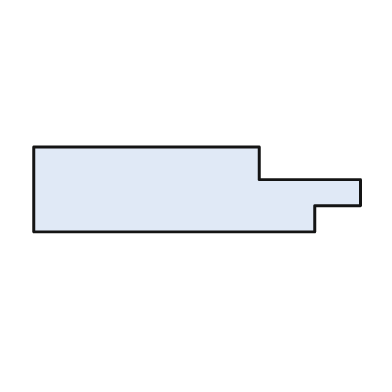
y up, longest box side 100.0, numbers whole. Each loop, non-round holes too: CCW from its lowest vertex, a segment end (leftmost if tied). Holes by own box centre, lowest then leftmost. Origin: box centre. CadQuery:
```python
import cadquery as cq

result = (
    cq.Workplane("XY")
    .moveTo(-50.0, -13.0)
    .lineTo(36.0, -13.0)
    .lineTo(36.0, -5.0)
    .lineTo(50.0, -5.0)
    .lineTo(50.0, 3.0)
    .lineTo(19.0, 3.0)
    .lineTo(19.0, 13.0)
    .lineTo(-50.0, 13.0)
    .close()
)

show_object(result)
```